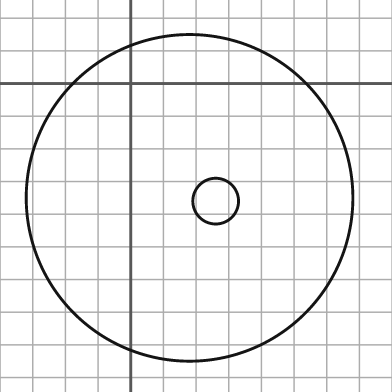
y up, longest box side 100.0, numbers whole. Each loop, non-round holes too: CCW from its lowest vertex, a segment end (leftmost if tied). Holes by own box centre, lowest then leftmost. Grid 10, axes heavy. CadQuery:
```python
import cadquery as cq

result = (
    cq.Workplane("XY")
    .moveTo(18.0, -35.0)
    .circle(50.0)
    .moveTo(26.0, -36.0)
    .circle(7.0)
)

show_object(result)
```